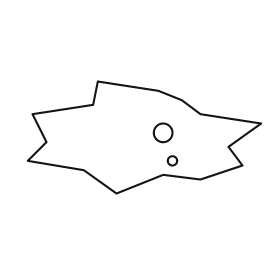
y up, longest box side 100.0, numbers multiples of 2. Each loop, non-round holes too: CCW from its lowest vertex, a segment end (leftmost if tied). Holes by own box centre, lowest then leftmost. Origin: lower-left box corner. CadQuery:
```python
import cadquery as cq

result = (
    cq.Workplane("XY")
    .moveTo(38.0, 0.0)
    .lineTo(58.0, 8.0)
    .lineTo(74.0, 6.0)
    .lineTo(92.0, 12.0)
    .lineTo(86.0, 20.0)
    .lineTo(100.0, 30.0)
    .lineTo(74.0, 34.0)
    .lineTo(66.0, 40.0)
    .lineTo(56.0, 44.0)
    .lineTo(30.0, 48.0)
    .lineTo(28.0, 38.0)
    .lineTo(2.0, 34.0)
    .lineTo(8.0, 22.0)
    .lineTo(0.0, 14.0)
    .lineTo(24.0, 10.0)
    .close()
    .moveTo(62.0, 14.0)
    .circle(2.0)
    .moveTo(58.0, 26.0)
    .circle(4.0)
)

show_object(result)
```